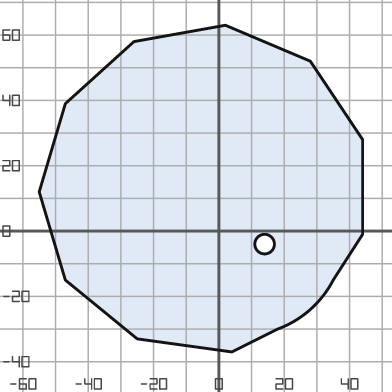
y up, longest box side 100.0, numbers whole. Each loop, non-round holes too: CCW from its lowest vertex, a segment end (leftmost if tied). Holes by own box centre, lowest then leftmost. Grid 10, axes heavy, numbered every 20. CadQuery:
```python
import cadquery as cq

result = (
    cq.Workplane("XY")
    .moveTo(4.0, -37.0)
    .lineTo(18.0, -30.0)
    .threePointArc((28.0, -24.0), (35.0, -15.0))
    .lineTo(44.0, -1.0)
    .lineTo(44.0, 28.0)
    .lineTo(28.0, 52.0)
    .lineTo(2.0, 63.0)
    .lineTo(-26.0, 58.0)
    .lineTo(-47.0, 39.0)
    .lineTo(-55.0, 12.0)
    .lineTo(-47.0, -15.0)
    .lineTo(-25.0, -33.0)
    .close()
    .moveTo(14.0, -4.0)
    .circle(3.0)
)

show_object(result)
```